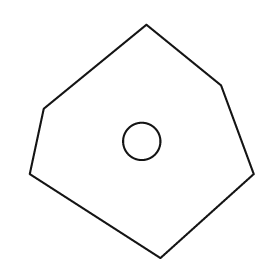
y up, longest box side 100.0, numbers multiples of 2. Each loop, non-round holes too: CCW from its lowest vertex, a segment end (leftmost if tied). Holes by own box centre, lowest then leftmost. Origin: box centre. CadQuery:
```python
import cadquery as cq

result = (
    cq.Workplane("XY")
    .moveTo(8.0, -50.0)
    .lineTo(48.0, -14.0)
    .lineTo(34.0, 24.0)
    .lineTo(2.0, 50.0)
    .lineTo(-42.0, 14.0)
    .lineTo(-48.0, -14.0)
    .close()
    .moveTo(0.0, 0.0)
    .circle(8.0)
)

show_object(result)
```